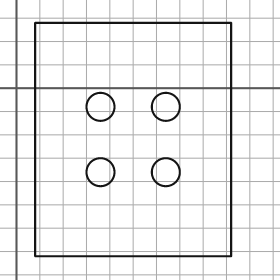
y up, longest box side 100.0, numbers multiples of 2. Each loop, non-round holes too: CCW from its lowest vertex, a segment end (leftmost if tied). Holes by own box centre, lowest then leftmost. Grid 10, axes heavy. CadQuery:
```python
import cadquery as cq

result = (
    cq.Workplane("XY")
    .moveTo(8.0, -72.0)
    .lineTo(92.0, -72.0)
    .lineTo(92.0, 28.0)
    .lineTo(8.0, 28.0)
    .close()
    .moveTo(36.0, -36.0)
    .circle(6.0)
    .moveTo(64.0, -36.0)
    .circle(6.0)
    .moveTo(36.0, -8.0)
    .circle(6.0)
    .moveTo(64.0, -8.0)
    .circle(6.0)
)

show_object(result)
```